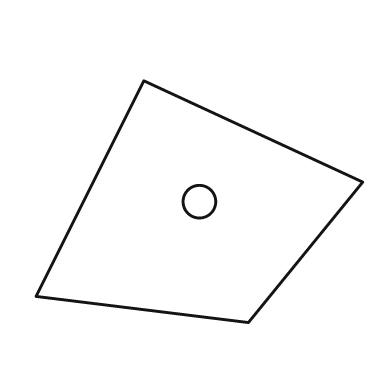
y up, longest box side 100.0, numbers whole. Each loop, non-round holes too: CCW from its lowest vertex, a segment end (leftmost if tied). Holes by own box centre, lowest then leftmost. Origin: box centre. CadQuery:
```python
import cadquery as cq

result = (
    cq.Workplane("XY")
    .moveTo(15.0, -37.0)
    .lineTo(50.0, 6.0)
    .lineTo(-17.0, 37.0)
    .lineTo(-50.0, -29.0)
    .close()
    .moveTo(0.0, 0.0)
    .circle(5.0)
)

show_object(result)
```